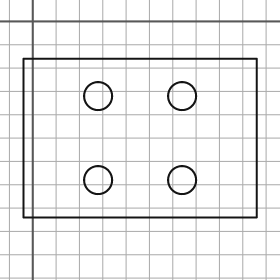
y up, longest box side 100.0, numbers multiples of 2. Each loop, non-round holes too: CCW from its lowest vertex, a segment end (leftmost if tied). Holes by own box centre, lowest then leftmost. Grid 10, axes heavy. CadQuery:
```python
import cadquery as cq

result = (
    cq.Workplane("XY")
    .moveTo(-4.0, -84.0)
    .lineTo(96.0, -84.0)
    .lineTo(96.0, -16.0)
    .lineTo(-4.0, -16.0)
    .close()
    .moveTo(28.0, -68.0)
    .circle(6.0)
    .moveTo(64.0, -68.0)
    .circle(6.0)
    .moveTo(28.0, -32.0)
    .circle(6.0)
    .moveTo(64.0, -32.0)
    .circle(6.0)
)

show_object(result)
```